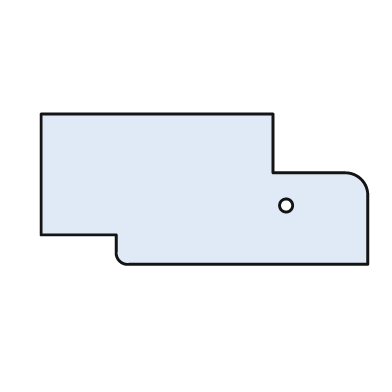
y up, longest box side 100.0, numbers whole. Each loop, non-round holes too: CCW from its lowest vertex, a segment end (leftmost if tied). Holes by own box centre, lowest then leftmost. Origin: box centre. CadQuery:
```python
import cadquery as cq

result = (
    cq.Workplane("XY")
    .moveTo(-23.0, -23.0)
    .lineTo(50.0, -23.0)
    .lineTo(50.0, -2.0)
    .threePointArc((48.0, 3.0), (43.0, 5.0))
    .lineTo(21.0, 5.0)
    .lineTo(21.0, 23.0)
    .lineTo(-50.0, 23.0)
    .lineTo(-50.0, -14.0)
    .lineTo(-27.0, -14.0)
    .lineTo(-27.0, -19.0)
    .threePointArc((-26.0, -22.0), (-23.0, -23.0))
    .close()
    .moveTo(25.0, -5.0)
    .circle(2.0)
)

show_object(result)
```